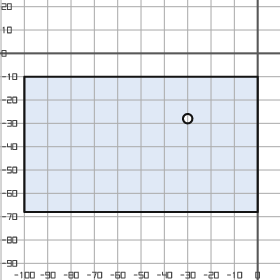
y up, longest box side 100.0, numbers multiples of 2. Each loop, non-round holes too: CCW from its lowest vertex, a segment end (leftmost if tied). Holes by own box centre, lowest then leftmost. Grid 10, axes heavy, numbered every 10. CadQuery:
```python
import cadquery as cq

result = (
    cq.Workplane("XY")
    .moveTo(-100.0, -68.0)
    .lineTo(0.0, -68.0)
    .lineTo(0.0, -10.0)
    .lineTo(-100.0, -10.0)
    .close()
    .moveTo(-30.0, -28.0)
    .circle(2.0)
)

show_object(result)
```